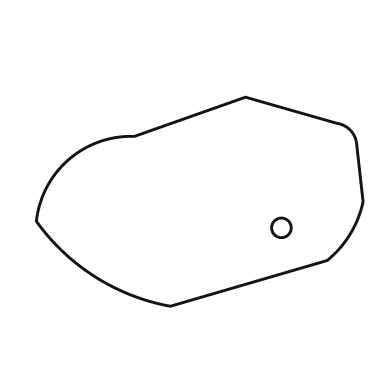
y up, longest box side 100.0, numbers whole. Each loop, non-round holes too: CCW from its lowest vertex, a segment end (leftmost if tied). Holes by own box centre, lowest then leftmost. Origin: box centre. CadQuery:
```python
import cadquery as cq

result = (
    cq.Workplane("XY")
    .moveTo(-9.0, -32.0)
    .lineTo(39.0, -18.0)
    .threePointArc((46.0, -10.0), (50.0, 0.0))
    .lineTo(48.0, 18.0)
    .threePointArc((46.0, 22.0), (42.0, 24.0))
    .lineTo(14.0, 32.0)
    .lineTo(-20.0, 20.0)
    .threePointArc((-40.0, 13.0), (-50.0, -6.0))
    .threePointArc((-32.0, -23.0), (-9.0, -32.0))
    .close()
    .moveTo(25.0, -8.0)
    .circle(3.0)
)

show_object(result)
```